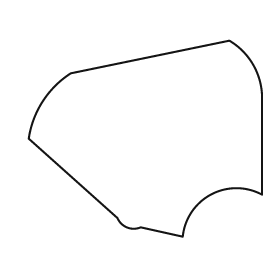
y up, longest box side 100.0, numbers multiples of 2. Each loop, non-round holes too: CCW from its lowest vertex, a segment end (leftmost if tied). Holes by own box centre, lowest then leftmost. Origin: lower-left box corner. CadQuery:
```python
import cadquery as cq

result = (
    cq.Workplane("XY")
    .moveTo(66.0, 0.0)
    .threePointArc((78.0, 18.0), (100.0, 18.0))
    .lineTo(100.0, 60.0)
    .threePointArc((96.0, 74.0), (86.0, 84.0))
    .lineTo(18.0, 70.0)
    .threePointArc((6.0, 58.0), (0.0, 42.0))
    .lineTo(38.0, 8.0)
    .threePointArc((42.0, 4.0), (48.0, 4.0))
    .close()
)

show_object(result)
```